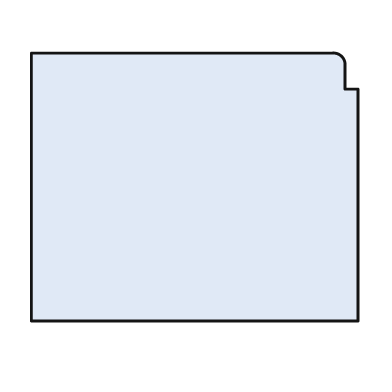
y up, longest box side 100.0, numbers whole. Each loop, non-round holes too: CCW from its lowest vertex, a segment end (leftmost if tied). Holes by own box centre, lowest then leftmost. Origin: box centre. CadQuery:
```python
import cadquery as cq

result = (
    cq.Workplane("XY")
    .moveTo(-50.0, -41.0)
    .lineTo(50.0, -41.0)
    .lineTo(50.0, 30.0)
    .lineTo(46.0, 30.0)
    .lineTo(46.0, 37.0)
    .threePointArc((45.0, 40.0), (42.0, 41.0))
    .lineTo(-50.0, 41.0)
    .close()
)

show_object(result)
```